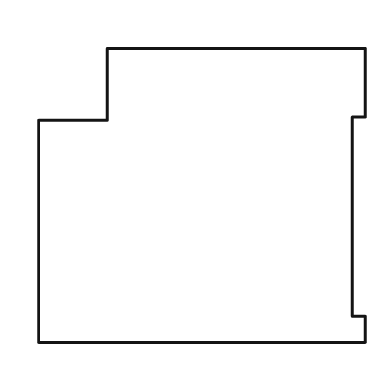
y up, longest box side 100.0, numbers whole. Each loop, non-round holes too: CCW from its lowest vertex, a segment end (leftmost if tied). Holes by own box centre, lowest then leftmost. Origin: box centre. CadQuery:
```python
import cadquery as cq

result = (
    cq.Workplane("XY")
    .moveTo(-50.0, -45.0)
    .lineTo(50.0, -45.0)
    .lineTo(50.0, -37.0)
    .lineTo(46.0, -37.0)
    .lineTo(46.0, 24.0)
    .lineTo(50.0, 24.0)
    .lineTo(50.0, 45.0)
    .lineTo(-29.0, 45.0)
    .lineTo(-29.0, 23.0)
    .lineTo(-50.0, 23.0)
    .close()
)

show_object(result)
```